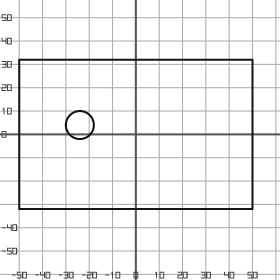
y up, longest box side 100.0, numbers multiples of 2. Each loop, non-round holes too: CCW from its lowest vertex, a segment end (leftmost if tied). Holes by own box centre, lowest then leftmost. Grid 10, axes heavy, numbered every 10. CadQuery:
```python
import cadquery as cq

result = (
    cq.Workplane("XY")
    .moveTo(-50.0, -32.0)
    .lineTo(50.0, -32.0)
    .lineTo(50.0, 32.0)
    .lineTo(-50.0, 32.0)
    .close()
    .moveTo(-24.0, 4.0)
    .circle(6.0)
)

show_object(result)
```